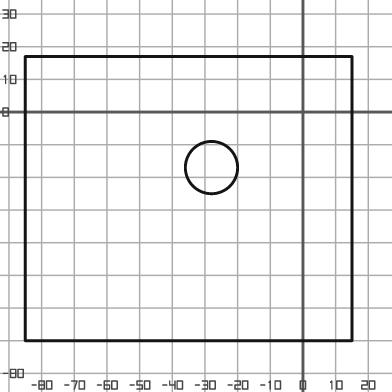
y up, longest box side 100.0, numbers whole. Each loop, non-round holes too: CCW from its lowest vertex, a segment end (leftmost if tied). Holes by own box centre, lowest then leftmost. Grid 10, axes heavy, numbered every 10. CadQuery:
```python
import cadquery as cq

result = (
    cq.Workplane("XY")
    .moveTo(-85.0, -70.0)
    .lineTo(15.0, -70.0)
    .lineTo(15.0, 17.0)
    .lineTo(-85.0, 17.0)
    .close()
    .moveTo(-28.0, -17.0)
    .circle(8.0)
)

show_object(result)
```